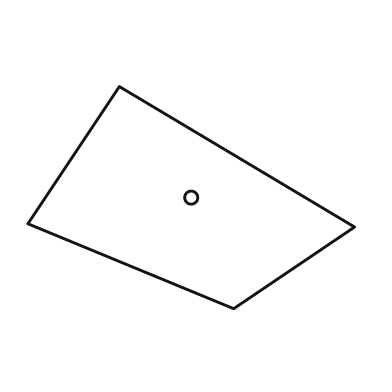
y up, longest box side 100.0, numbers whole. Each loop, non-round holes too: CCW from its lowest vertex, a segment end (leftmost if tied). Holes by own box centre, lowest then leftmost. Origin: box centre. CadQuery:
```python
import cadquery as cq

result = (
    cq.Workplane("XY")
    .moveTo(13.0, -34.0)
    .lineTo(50.0, -9.0)
    .lineTo(-22.0, 34.0)
    .lineTo(-50.0, -8.0)
    .close()
    .moveTo(0.0, 0.0)
    .circle(2.0)
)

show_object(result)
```